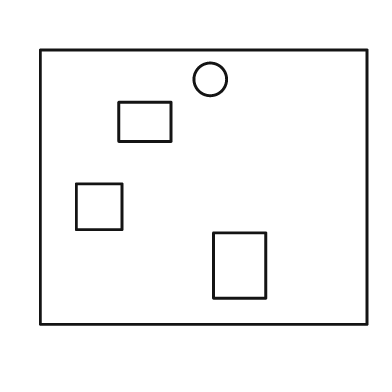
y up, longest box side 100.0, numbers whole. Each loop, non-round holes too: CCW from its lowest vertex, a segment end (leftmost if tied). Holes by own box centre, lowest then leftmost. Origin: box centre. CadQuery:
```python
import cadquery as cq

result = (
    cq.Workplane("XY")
    .moveTo(-50.0, -42.0)
    .lineTo(50.0, -42.0)
    .lineTo(50.0, 42.0)
    .lineTo(-50.0, 42.0)
    .close()
    .moveTo(3.0, -34.0)
    .lineTo(19.0, -34.0)
    .lineTo(19.0, -14.0)
    .lineTo(3.0, -14.0)
    .close()
    .moveTo(-39.0, -13.0)
    .lineTo(-25.0, -13.0)
    .lineTo(-25.0, 1.0)
    .lineTo(-39.0, 1.0)
    .close()
    .moveTo(-26.0, 14.0)
    .lineTo(-10.0, 14.0)
    .lineTo(-10.0, 26.0)
    .lineTo(-26.0, 26.0)
    .close()
    .moveTo(2.0, 33.0)
    .circle(5.0)
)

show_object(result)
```